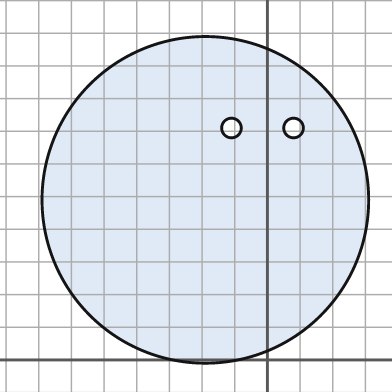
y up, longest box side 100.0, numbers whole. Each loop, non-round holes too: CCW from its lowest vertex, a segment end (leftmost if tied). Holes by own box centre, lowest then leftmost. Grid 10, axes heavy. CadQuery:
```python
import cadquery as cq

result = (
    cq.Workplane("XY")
    .moveTo(-19.0, 49.0)
    .circle(50.0)
    .moveTo(-11.0, 71.0)
    .circle(3.0)
    .moveTo(8.0, 71.0)
    .circle(3.0)
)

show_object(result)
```